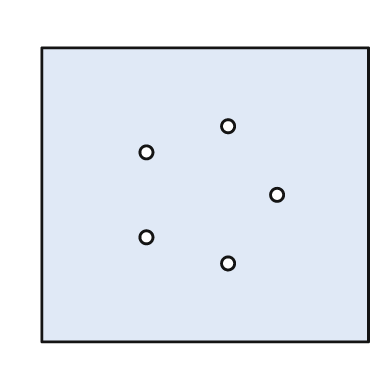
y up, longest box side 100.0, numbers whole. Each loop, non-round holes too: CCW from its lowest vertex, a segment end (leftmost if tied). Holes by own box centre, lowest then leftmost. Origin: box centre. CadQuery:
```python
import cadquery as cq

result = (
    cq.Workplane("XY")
    .moveTo(-50.0, -45.0)
    .lineTo(50.0, -45.0)
    .lineTo(50.0, 45.0)
    .lineTo(-50.0, 45.0)
    .close()
    .moveTo(7.0, -21.0)
    .circle(2.0)
    .moveTo(-18.0, -13.0)
    .circle(2.0)
    .moveTo(22.0, 0.0)
    .circle(2.0)
    .moveTo(-18.0, 13.0)
    .circle(2.0)
    .moveTo(7.0, 21.0)
    .circle(2.0)
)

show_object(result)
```